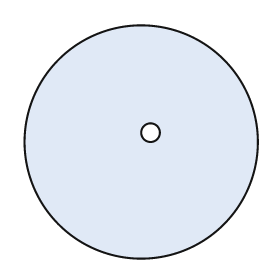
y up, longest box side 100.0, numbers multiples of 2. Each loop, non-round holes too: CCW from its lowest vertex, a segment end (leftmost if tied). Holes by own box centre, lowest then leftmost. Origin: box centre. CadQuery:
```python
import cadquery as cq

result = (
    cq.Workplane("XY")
    .moveTo(0.0, 0.0)
    .circle(50.0)
    .moveTo(4.0, 4.0)
    .circle(4.0)
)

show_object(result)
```